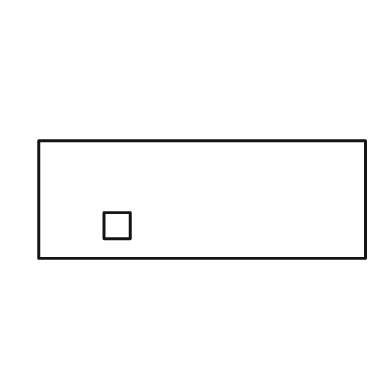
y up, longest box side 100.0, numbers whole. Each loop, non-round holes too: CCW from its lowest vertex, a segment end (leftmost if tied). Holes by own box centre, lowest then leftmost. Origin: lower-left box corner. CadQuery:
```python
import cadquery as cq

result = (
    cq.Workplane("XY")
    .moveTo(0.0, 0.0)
    .lineTo(100.0, 0.0)
    .lineTo(100.0, 36.0)
    .lineTo(0.0, 36.0)
    .close()
    .moveTo(20.0, 6.0)
    .lineTo(28.0, 6.0)
    .lineTo(28.0, 14.0)
    .lineTo(20.0, 14.0)
    .close()
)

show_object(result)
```